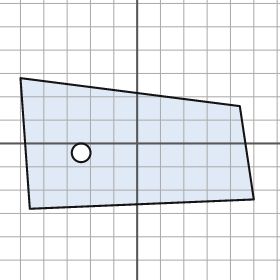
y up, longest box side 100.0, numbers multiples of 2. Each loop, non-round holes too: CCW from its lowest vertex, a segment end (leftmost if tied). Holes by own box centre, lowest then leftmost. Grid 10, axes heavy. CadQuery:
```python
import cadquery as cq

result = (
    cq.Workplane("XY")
    .moveTo(-46.0, -28.0)
    .lineTo(50.0, -24.0)
    .lineTo(44.0, 16.0)
    .lineTo(-50.0, 28.0)
    .close()
    .moveTo(-24.0, -4.0)
    .circle(4.0)
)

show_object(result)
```